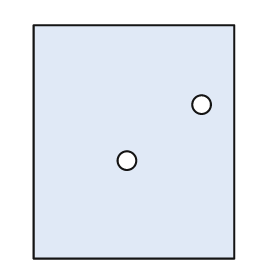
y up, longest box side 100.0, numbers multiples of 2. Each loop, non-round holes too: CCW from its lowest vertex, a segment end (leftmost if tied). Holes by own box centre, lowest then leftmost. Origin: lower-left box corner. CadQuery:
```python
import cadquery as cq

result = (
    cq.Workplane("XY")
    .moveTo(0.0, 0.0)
    .lineTo(86.0, 0.0)
    .lineTo(86.0, 100.0)
    .lineTo(0.0, 100.0)
    .close()
    .moveTo(40.0, 42.0)
    .circle(4.0)
    .moveTo(72.0, 66.0)
    .circle(4.0)
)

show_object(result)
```